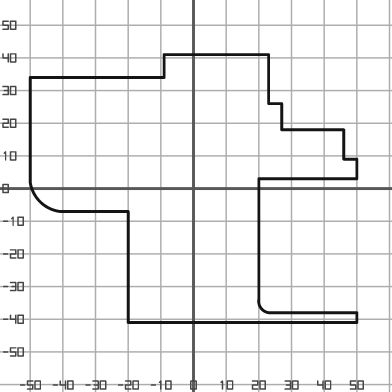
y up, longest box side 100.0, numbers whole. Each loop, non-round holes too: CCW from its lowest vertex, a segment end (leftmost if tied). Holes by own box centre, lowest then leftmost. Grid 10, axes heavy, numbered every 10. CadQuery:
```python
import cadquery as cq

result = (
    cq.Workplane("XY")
    .moveTo(-20.0, -41.0)
    .lineTo(50.0, -41.0)
    .lineTo(50.0, -38.0)
    .lineTo(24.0, -38.0)
    .threePointArc((21.0, -37.0), (20.0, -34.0))
    .lineTo(20.0, 3.0)
    .lineTo(50.0, 3.0)
    .lineTo(50.0, 9.0)
    .lineTo(46.0, 9.0)
    .lineTo(46.0, 18.0)
    .lineTo(27.0, 18.0)
    .lineTo(27.0, 26.0)
    .lineTo(23.0, 26.0)
    .lineTo(23.0, 41.0)
    .lineTo(-9.0, 41.0)
    .lineTo(-9.0, 34.0)
    .lineTo(-50.0, 34.0)
    .lineTo(-50.0, 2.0)
    .threePointArc((-47.0, -4.0), (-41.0, -7.0))
    .lineTo(-20.0, -7.0)
    .close()
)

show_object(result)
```